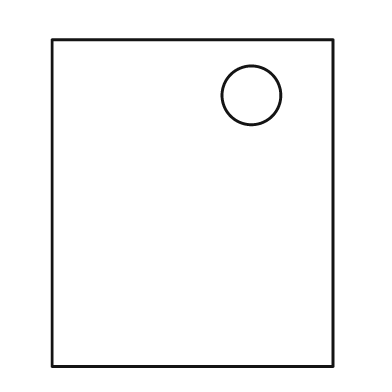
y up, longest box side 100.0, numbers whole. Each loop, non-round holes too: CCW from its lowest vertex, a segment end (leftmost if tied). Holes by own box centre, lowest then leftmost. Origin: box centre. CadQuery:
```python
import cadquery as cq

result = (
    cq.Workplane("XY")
    .moveTo(-43.0, -50.0)
    .lineTo(43.0, -50.0)
    .lineTo(43.0, 50.0)
    .lineTo(-43.0, 50.0)
    .close()
    .moveTo(18.0, 33.0)
    .circle(9.0)
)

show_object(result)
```